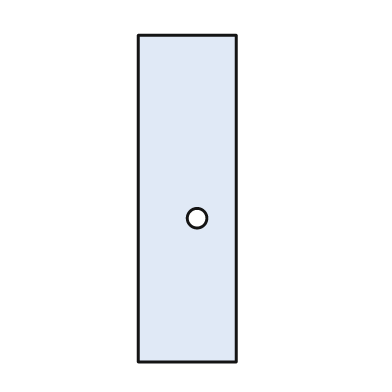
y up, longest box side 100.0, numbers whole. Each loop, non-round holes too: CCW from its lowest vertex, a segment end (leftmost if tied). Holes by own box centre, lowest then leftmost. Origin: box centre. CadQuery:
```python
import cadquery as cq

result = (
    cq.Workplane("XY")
    .moveTo(-15.0, -50.0)
    .lineTo(15.0, -50.0)
    .lineTo(15.0, 50.0)
    .lineTo(-15.0, 50.0)
    .close()
    .moveTo(3.0, -6.0)
    .circle(3.0)
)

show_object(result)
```